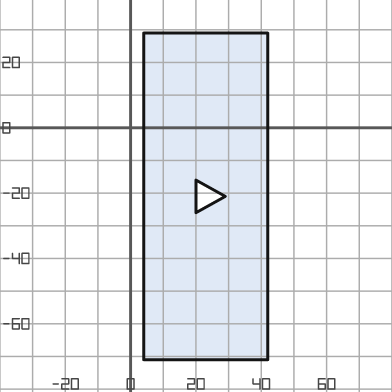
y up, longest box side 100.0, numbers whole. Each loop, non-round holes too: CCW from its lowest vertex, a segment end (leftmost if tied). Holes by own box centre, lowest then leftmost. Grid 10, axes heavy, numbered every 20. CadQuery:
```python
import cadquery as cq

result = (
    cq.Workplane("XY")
    .moveTo(4.0, -71.0)
    .lineTo(42.0, -71.0)
    .lineTo(42.0, 29.0)
    .lineTo(4.0, 29.0)
    .close()
    .moveTo(20.0, -26.0)
    .lineTo(29.0, -21.0)
    .lineTo(20.0, -16.0)
    .close()
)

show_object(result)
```